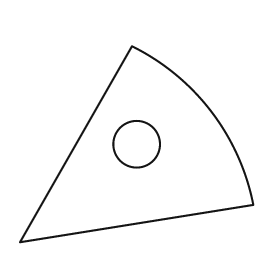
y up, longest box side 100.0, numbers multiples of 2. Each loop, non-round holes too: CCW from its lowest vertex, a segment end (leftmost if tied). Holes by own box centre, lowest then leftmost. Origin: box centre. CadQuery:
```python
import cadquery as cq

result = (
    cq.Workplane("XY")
    .moveTo(-50.0, -42.0)
    .lineTo(50.0, -26.0)
    .threePointArc((32.0, 14.0), (-2.0, 42.0))
    .close()
    .moveTo(0.0, 0.0)
    .circle(10.0)
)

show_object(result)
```